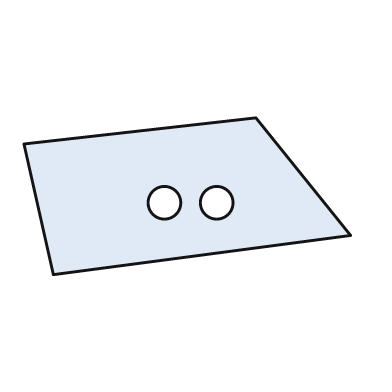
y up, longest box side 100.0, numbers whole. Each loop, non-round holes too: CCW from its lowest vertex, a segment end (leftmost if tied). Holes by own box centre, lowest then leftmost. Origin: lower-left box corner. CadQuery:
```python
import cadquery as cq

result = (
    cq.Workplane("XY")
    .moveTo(9.0, 0.0)
    .lineTo(100.0, 12.0)
    .lineTo(71.0, 48.0)
    .lineTo(0.0, 40.0)
    .close()
    .moveTo(43.0, 22.0)
    .circle(5.0)
    .moveTo(59.0, 22.0)
    .circle(5.0)
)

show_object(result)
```